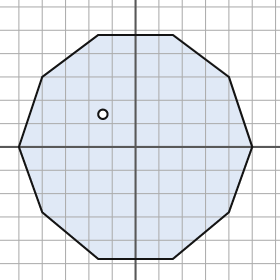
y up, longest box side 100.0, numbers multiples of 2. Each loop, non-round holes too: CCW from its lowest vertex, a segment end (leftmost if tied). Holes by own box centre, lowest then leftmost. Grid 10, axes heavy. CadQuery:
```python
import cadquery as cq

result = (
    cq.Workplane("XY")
    .moveTo(-16.0, -48.0)
    .lineTo(16.0, -48.0)
    .lineTo(40.0, -28.0)
    .lineTo(50.0, 0.0)
    .lineTo(40.0, 30.0)
    .lineTo(16.0, 48.0)
    .lineTo(-16.0, 48.0)
    .lineTo(-40.0, 30.0)
    .lineTo(-50.0, 0.0)
    .lineTo(-40.0, -28.0)
    .close()
    .moveTo(-14.0, 14.0)
    .circle(2.0)
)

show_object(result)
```